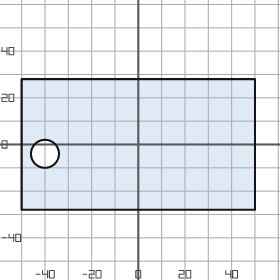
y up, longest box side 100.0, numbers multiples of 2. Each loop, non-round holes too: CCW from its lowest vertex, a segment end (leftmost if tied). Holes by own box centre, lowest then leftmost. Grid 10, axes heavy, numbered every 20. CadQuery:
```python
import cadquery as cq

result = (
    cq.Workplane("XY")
    .moveTo(-50.0, -28.0)
    .lineTo(50.0, -28.0)
    .lineTo(50.0, 28.0)
    .lineTo(-50.0, 28.0)
    .close()
    .moveTo(-40.0, -4.0)
    .circle(6.0)
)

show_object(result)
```